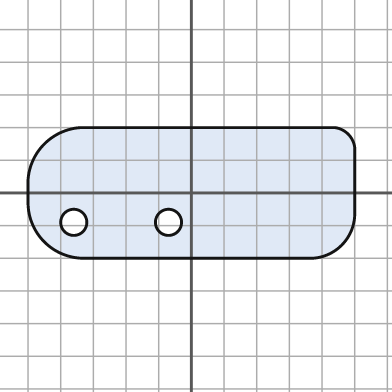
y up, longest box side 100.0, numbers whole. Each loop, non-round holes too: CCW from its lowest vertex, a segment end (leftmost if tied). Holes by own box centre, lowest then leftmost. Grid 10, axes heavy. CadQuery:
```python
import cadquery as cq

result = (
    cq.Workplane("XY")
    .moveTo(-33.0, -20.0)
    .lineTo(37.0, -20.0)
    .threePointArc((46.0, -16.0), (50.0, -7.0))
    .lineTo(50.0, 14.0)
    .threePointArc((48.0, 18.0), (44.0, 20.0))
    .lineTo(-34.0, 20.0)
    .threePointArc((-45.0, 15.0), (-50.0, 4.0))
    .lineTo(-50.0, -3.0)
    .threePointArc((-45.0, -15.0), (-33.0, -20.0))
    .close()
    .moveTo(-36.0, -9.0)
    .circle(4.0)
    .moveTo(-7.0, -9.0)
    .circle(4.0)
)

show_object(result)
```